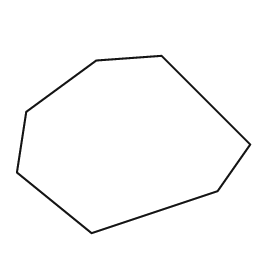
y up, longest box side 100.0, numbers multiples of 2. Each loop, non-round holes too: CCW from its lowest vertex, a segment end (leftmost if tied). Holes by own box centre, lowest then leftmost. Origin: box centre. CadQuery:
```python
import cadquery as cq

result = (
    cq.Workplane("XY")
    .moveTo(-18.0, -38.0)
    .lineTo(36.0, -20.0)
    .lineTo(50.0, 0.0)
    .lineTo(12.0, 38.0)
    .lineTo(-16.0, 36.0)
    .lineTo(-46.0, 14.0)
    .lineTo(-50.0, -12.0)
    .close()
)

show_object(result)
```